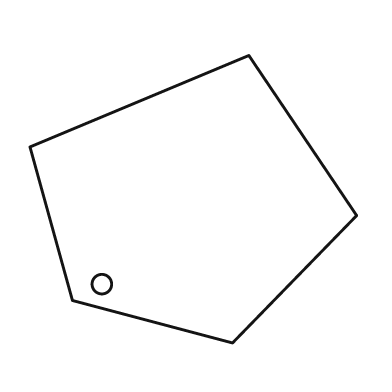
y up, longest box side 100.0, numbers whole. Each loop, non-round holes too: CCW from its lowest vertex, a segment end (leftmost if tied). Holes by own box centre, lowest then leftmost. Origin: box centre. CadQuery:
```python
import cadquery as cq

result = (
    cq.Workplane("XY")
    .moveTo(12.0, -44.0)
    .lineTo(50.0, -5.0)
    .lineTo(17.0, 44.0)
    .lineTo(-50.0, 16.0)
    .lineTo(-37.0, -31.0)
    .close()
    .moveTo(-28.0, -26.0)
    .circle(3.0)
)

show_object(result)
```